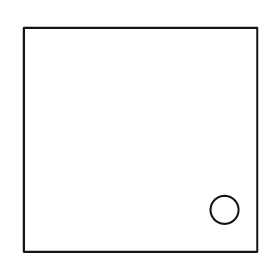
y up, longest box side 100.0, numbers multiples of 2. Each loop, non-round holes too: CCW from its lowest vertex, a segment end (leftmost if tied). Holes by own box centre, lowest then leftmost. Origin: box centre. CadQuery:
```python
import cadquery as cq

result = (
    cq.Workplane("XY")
    .moveTo(-50.0, -48.0)
    .lineTo(50.0, -48.0)
    .lineTo(50.0, 48.0)
    .lineTo(-50.0, 48.0)
    .close()
    .moveTo(36.0, -30.0)
    .circle(6.0)
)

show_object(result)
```